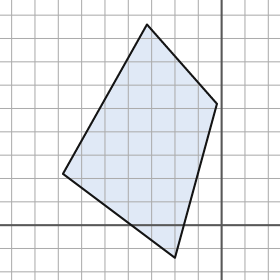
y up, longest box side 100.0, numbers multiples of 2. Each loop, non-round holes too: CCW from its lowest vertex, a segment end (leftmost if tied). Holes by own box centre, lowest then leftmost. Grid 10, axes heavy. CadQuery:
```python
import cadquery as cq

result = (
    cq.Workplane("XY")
    .moveTo(-20.0, -14.0)
    .lineTo(-2.0, 52.0)
    .lineTo(-32.0, 86.0)
    .lineTo(-68.0, 22.0)
    .close()
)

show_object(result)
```